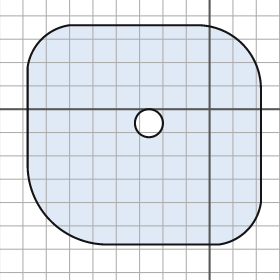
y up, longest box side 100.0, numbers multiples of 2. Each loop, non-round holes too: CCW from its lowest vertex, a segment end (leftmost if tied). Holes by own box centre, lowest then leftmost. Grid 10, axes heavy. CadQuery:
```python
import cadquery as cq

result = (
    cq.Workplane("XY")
    .moveTo(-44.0, -58.0)
    .lineTo(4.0, -58.0)
    .threePointArc((16.0, -52.0), (22.0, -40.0))
    .lineTo(22.0, 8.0)
    .threePointArc((14.0, 28.0), (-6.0, 36.0))
    .lineTo(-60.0, 36.0)
    .threePointArc((-72.0, 30.0), (-78.0, 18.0))
    .lineTo(-78.0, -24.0)
    .threePointArc((-68.0, -48.0), (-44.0, -58.0))
    .close()
    .moveTo(-26.0, -6.0)
    .circle(6.0)
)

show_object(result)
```